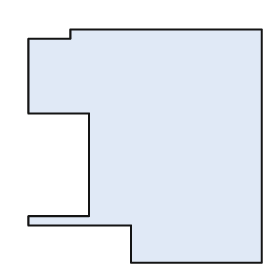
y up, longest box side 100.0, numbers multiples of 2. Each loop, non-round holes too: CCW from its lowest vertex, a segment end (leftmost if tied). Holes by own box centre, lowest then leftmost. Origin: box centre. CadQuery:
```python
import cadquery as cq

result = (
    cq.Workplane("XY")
    .moveTo(-6.0, -50.0)
    .lineTo(50.0, -50.0)
    .lineTo(50.0, 50.0)
    .lineTo(-32.0, 50.0)
    .lineTo(-32.0, 46.0)
    .lineTo(-50.0, 46.0)
    .lineTo(-50.0, 14.0)
    .lineTo(-24.0, 14.0)
    .lineTo(-24.0, -30.0)
    .lineTo(-50.0, -30.0)
    .lineTo(-50.0, -34.0)
    .lineTo(-6.0, -34.0)
    .close()
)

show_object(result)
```